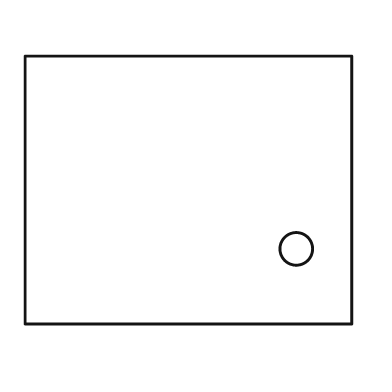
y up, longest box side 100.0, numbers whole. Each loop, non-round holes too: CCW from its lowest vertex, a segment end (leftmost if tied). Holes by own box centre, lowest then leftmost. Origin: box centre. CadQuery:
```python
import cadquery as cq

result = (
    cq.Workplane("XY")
    .moveTo(-50.0, -41.0)
    .lineTo(50.0, -41.0)
    .lineTo(50.0, 41.0)
    .lineTo(-50.0, 41.0)
    .close()
    .moveTo(33.0, -18.0)
    .circle(5.0)
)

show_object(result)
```